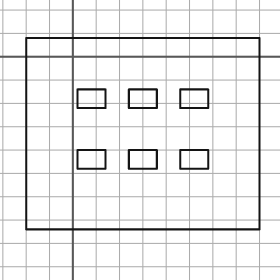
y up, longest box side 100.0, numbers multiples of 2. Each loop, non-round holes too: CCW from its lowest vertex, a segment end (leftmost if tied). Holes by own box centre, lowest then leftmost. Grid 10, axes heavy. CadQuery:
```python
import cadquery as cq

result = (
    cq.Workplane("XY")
    .moveTo(-20.0, -74.0)
    .lineTo(80.0, -74.0)
    .lineTo(80.0, 8.0)
    .lineTo(-20.0, 8.0)
    .close()
    .moveTo(2.0, -48.0)
    .lineTo(14.0, -48.0)
    .lineTo(14.0, -40.0)
    .lineTo(2.0, -40.0)
    .close()
    .moveTo(24.0, -48.0)
    .lineTo(36.0, -48.0)
    .lineTo(36.0, -40.0)
    .lineTo(24.0, -40.0)
    .close()
    .moveTo(46.0, -48.0)
    .lineTo(58.0, -48.0)
    .lineTo(58.0, -40.0)
    .lineTo(46.0, -40.0)
    .close()
    .moveTo(2.0, -22.0)
    .lineTo(14.0, -22.0)
    .lineTo(14.0, -14.0)
    .lineTo(2.0, -14.0)
    .close()
    .moveTo(24.0, -22.0)
    .lineTo(36.0, -22.0)
    .lineTo(36.0, -14.0)
    .lineTo(24.0, -14.0)
    .close()
    .moveTo(46.0, -22.0)
    .lineTo(58.0, -22.0)
    .lineTo(58.0, -14.0)
    .lineTo(46.0, -14.0)
    .close()
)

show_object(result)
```